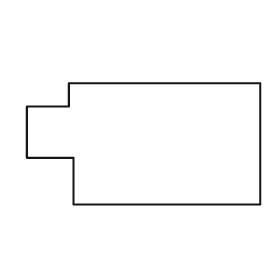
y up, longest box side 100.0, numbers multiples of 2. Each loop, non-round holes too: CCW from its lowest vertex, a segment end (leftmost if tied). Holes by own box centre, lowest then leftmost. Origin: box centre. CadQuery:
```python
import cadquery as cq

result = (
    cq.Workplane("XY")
    .moveTo(-30.0, -26.0)
    .lineTo(50.0, -26.0)
    .lineTo(50.0, 26.0)
    .lineTo(-32.0, 26.0)
    .lineTo(-32.0, 16.0)
    .lineTo(-50.0, 16.0)
    .lineTo(-50.0, -6.0)
    .lineTo(-30.0, -6.0)
    .close()
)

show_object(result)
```